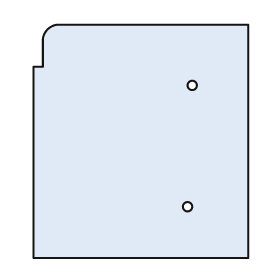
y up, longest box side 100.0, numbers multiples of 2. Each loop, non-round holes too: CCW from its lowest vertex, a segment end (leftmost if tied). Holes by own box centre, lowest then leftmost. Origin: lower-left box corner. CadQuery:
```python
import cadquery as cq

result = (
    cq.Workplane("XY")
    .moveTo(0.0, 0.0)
    .lineTo(92.0, 0.0)
    .lineTo(92.0, 100.0)
    .lineTo(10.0, 100.0)
    .threePointArc((6.0, 98.0), (4.0, 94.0))
    .lineTo(4.0, 82.0)
    .lineTo(0.0, 82.0)
    .close()
    .moveTo(66.0, 22.0)
    .circle(2.0)
    .moveTo(68.0, 74.0)
    .circle(2.0)
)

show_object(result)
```